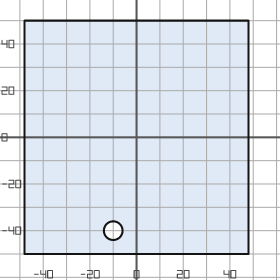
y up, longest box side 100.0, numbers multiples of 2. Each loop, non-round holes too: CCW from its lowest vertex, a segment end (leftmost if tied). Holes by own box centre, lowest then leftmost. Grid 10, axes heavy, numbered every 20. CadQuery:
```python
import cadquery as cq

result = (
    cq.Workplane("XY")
    .moveTo(-48.0, -50.0)
    .lineTo(48.0, -50.0)
    .lineTo(48.0, 50.0)
    .lineTo(-48.0, 50.0)
    .close()
    .moveTo(-10.0, -40.0)
    .circle(4.0)
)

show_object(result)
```